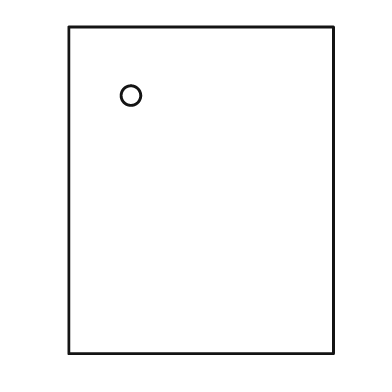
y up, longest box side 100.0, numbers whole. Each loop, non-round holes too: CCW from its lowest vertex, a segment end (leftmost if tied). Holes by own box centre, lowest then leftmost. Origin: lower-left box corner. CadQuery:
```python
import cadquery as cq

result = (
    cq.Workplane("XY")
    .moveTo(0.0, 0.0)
    .lineTo(81.0, 0.0)
    .lineTo(81.0, 100.0)
    .lineTo(0.0, 100.0)
    .close()
    .moveTo(19.0, 79.0)
    .circle(3.0)
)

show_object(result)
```